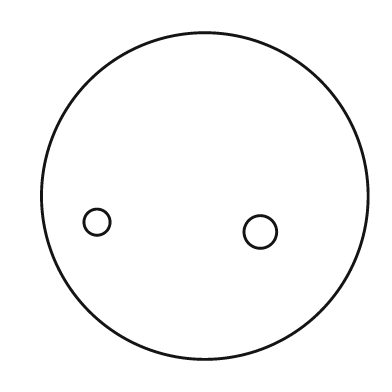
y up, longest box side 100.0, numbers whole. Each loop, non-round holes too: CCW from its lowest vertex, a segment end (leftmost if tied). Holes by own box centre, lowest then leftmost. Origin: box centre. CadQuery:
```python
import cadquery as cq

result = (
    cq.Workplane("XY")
    .moveTo(0.0, 0.0)
    .circle(50.0)
    .moveTo(17.0, -11.0)
    .circle(5.0)
    .moveTo(-33.0, -8.0)
    .circle(4.0)
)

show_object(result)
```